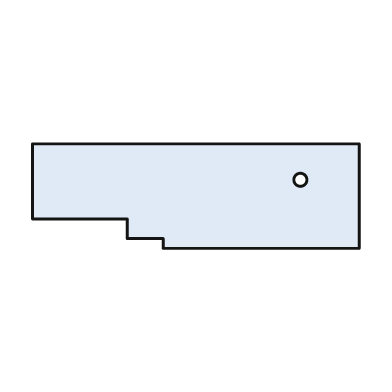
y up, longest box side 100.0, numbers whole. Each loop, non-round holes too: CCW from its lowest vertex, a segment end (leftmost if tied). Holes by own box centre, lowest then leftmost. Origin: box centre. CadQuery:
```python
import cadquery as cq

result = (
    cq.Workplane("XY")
    .moveTo(-10.0, -16.0)
    .lineTo(50.0, -16.0)
    .lineTo(50.0, 16.0)
    .lineTo(-50.0, 16.0)
    .lineTo(-50.0, -7.0)
    .lineTo(-21.0, -7.0)
    .lineTo(-21.0, -13.0)
    .lineTo(-10.0, -13.0)
    .close()
    .moveTo(32.0, 5.0)
    .circle(2.0)
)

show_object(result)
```